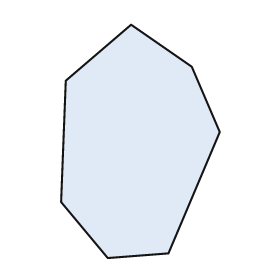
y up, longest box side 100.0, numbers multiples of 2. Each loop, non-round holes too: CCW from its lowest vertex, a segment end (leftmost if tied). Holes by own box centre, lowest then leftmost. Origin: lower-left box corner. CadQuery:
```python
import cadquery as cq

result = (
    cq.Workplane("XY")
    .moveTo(20.0, 0.0)
    .lineTo(46.0, 2.0)
    .lineTo(68.0, 54.0)
    .lineTo(56.0, 82.0)
    .lineTo(30.0, 100.0)
    .lineTo(2.0, 76.0)
    .lineTo(0.0, 24.0)
    .close()
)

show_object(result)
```